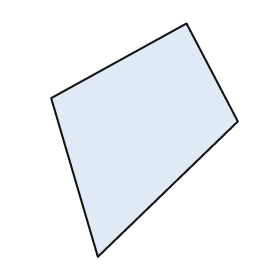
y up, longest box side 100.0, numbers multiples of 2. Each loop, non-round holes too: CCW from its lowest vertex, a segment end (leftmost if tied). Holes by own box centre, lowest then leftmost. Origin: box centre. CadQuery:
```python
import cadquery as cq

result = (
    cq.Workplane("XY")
    .moveTo(-20.0, -50.0)
    .lineTo(40.0, 8.0)
    .lineTo(18.0, 50.0)
    .lineTo(-40.0, 18.0)
    .close()
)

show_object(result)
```